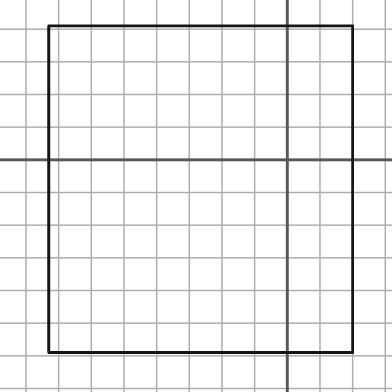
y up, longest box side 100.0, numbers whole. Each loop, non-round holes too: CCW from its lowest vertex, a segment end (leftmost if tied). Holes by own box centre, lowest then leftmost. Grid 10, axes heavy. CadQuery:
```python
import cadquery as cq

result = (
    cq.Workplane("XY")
    .moveTo(-73.0, -59.0)
    .lineTo(20.0, -59.0)
    .lineTo(20.0, 41.0)
    .lineTo(-73.0, 41.0)
    .close()
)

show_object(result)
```